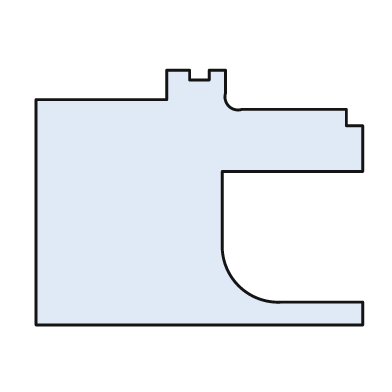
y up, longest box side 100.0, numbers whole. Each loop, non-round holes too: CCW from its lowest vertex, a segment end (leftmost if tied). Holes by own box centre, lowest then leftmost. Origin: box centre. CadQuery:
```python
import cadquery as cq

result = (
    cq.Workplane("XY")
    .moveTo(-50.0, -39.0)
    .lineTo(50.0, -39.0)
    .lineTo(50.0, -32.0)
    .lineTo(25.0, -32.0)
    .threePointArc((12.0, -27.0), (7.0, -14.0))
    .lineTo(7.0, 8.0)
    .lineTo(50.0, 8.0)
    .lineTo(50.0, 22.0)
    .lineTo(45.0, 22.0)
    .lineTo(45.0, 27.0)
    .lineTo(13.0, 27.0)
    .threePointArc((9.0, 28.0), (8.0, 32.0))
    .lineTo(8.0, 39.0)
    .lineTo(3.0, 39.0)
    .lineTo(3.0, 36.0)
    .lineTo(-3.0, 36.0)
    .lineTo(-3.0, 39.0)
    .lineTo(-10.0, 39.0)
    .lineTo(-10.0, 30.0)
    .lineTo(-50.0, 30.0)
    .close()
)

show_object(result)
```